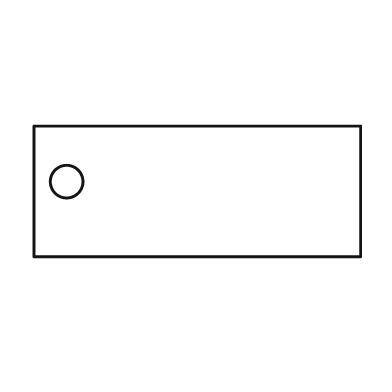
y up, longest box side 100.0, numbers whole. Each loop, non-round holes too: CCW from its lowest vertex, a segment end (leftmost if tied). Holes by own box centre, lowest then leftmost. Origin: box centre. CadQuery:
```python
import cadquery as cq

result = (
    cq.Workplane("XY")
    .moveTo(-50.0, -20.0)
    .lineTo(50.0, -20.0)
    .lineTo(50.0, 20.0)
    .lineTo(-50.0, 20.0)
    .close()
    .moveTo(-40.0, 3.0)
    .circle(5.0)
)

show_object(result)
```